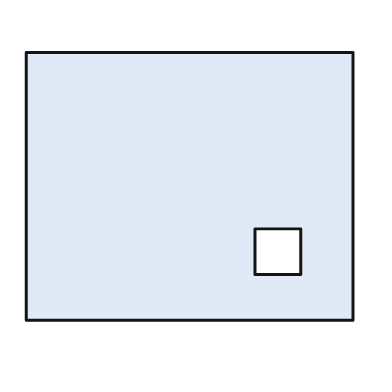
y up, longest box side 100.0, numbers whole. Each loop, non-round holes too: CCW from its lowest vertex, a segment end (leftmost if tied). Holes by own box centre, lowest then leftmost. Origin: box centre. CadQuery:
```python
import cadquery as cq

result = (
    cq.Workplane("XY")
    .moveTo(-50.0, -41.0)
    .lineTo(50.0, -41.0)
    .lineTo(50.0, 41.0)
    .lineTo(-50.0, 41.0)
    .close()
    .moveTo(20.0, -27.0)
    .lineTo(34.0, -27.0)
    .lineTo(34.0, -13.0)
    .lineTo(20.0, -13.0)
    .close()
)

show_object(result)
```